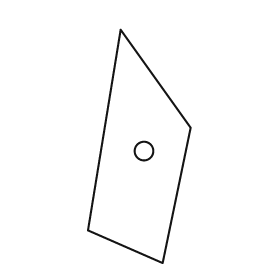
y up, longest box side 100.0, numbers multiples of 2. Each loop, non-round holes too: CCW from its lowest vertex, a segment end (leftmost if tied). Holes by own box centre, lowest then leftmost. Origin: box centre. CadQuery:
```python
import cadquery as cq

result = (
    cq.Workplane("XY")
    .moveTo(10.0, -50.0)
    .lineTo(22.0, 8.0)
    .lineTo(-8.0, 50.0)
    .lineTo(-22.0, -36.0)
    .close()
    .moveTo(2.0, -2.0)
    .circle(4.0)
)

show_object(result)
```